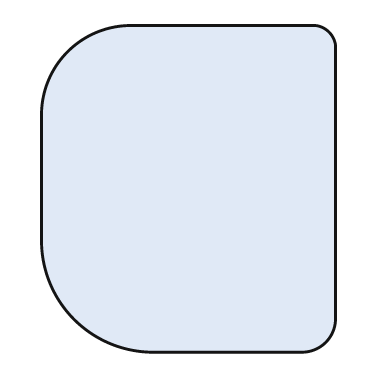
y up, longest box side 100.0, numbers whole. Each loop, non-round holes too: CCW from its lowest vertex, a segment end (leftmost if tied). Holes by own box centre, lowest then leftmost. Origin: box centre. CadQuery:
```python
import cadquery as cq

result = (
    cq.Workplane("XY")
    .moveTo(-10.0, -50.0)
    .lineTo(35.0, -50.0)
    .threePointArc((42.0, -47.0), (45.0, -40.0))
    .lineTo(45.0, 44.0)
    .threePointArc((43.0, 48.0), (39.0, 50.0))
    .lineTo(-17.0, 50.0)
    .threePointArc((-37.0, 42.0), (-45.0, 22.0))
    .lineTo(-45.0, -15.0)
    .threePointArc((-35.0, -40.0), (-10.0, -50.0))
    .close()
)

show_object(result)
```